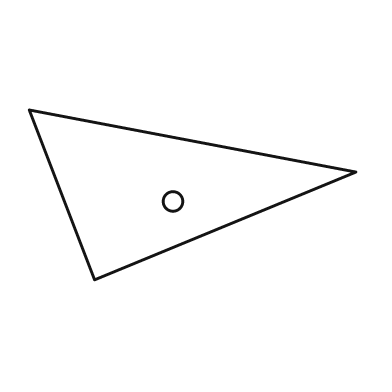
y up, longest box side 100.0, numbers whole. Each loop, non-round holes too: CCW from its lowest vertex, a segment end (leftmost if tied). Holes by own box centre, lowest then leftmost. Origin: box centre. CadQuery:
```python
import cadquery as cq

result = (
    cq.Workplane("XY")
    .moveTo(-30.0, -26.0)
    .lineTo(50.0, 7.0)
    .lineTo(-50.0, 26.0)
    .close()
    .moveTo(-6.0, -2.0)
    .circle(3.0)
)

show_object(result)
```